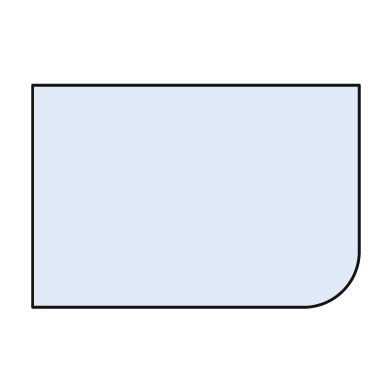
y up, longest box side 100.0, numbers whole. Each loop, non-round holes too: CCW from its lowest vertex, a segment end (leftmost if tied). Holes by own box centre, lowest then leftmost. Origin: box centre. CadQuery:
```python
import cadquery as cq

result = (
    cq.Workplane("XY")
    .moveTo(-50.0, -34.0)
    .lineTo(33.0, -34.0)
    .threePointArc((45.0, -29.0), (50.0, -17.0))
    .lineTo(50.0, 34.0)
    .lineTo(-50.0, 34.0)
    .close()
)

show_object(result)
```